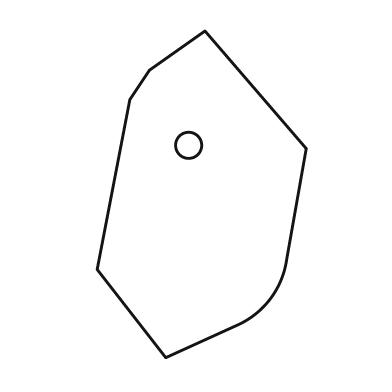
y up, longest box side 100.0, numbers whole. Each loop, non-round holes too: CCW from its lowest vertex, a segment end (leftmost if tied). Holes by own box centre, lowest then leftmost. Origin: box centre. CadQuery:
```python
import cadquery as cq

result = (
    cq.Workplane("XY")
    .moveTo(-11.0, -50.0)
    .lineTo(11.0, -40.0)
    .threePointArc((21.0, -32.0), (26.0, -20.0))
    .lineTo(32.0, 14.0)
    .lineTo(1.0, 50.0)
    .lineTo(-16.0, 38.0)
    .lineTo(-22.0, 29.0)
    .lineTo(-32.0, -23.0)
    .close()
    .moveTo(-4.0, 15.0)
    .circle(4.0)
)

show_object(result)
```